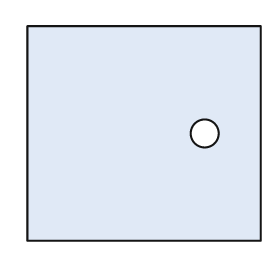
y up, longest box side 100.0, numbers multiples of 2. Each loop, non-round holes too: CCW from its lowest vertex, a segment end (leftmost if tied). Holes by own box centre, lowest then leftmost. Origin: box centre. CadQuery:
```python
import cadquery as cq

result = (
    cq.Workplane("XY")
    .moveTo(-50.0, -46.0)
    .lineTo(50.0, -46.0)
    .lineTo(50.0, 46.0)
    .lineTo(-50.0, 46.0)
    .close()
    .moveTo(26.0, 0.0)
    .circle(6.0)
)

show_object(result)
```